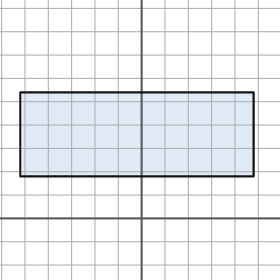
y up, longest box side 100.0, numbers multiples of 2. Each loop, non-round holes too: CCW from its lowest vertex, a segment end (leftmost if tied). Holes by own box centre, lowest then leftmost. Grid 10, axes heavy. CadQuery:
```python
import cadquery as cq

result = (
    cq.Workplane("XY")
    .moveTo(-52.0, 18.0)
    .lineTo(48.0, 18.0)
    .lineTo(48.0, 54.0)
    .lineTo(-52.0, 54.0)
    .close()
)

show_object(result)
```